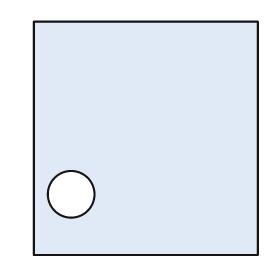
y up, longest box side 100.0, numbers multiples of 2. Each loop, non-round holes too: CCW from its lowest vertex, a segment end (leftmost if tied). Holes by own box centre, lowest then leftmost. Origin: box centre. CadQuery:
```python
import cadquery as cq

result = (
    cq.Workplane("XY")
    .moveTo(-48.0, -50.0)
    .lineTo(48.0, -50.0)
    .lineTo(48.0, 50.0)
    .lineTo(-48.0, 50.0)
    .close()
    .moveTo(-32.0, -24.0)
    .circle(10.0)
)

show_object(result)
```